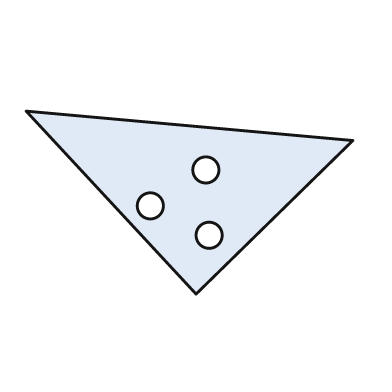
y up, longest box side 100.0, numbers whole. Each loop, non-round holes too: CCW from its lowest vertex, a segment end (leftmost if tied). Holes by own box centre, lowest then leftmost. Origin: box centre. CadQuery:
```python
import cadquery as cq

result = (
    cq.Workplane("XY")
    .moveTo(2.0, -28.0)
    .lineTo(50.0, 19.0)
    .lineTo(-50.0, 28.0)
    .close()
    .moveTo(6.0, -10.0)
    .circle(4.0)
    .moveTo(-12.0, -1.0)
    .circle(4.0)
    .moveTo(5.0, 10.0)
    .circle(4.0)
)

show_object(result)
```